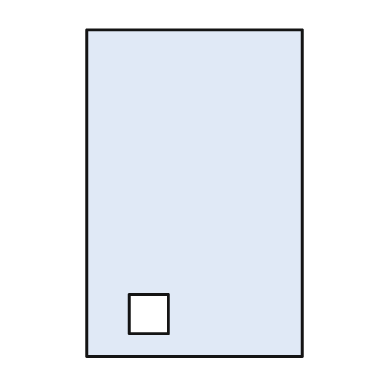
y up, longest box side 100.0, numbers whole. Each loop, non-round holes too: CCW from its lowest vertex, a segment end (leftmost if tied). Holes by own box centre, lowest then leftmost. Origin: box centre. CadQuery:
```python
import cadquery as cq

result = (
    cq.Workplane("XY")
    .moveTo(-33.0, -50.0)
    .lineTo(33.0, -50.0)
    .lineTo(33.0, 50.0)
    .lineTo(-33.0, 50.0)
    .close()
    .moveTo(-20.0, -43.0)
    .lineTo(-8.0, -43.0)
    .lineTo(-8.0, -31.0)
    .lineTo(-20.0, -31.0)
    .close()
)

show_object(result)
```